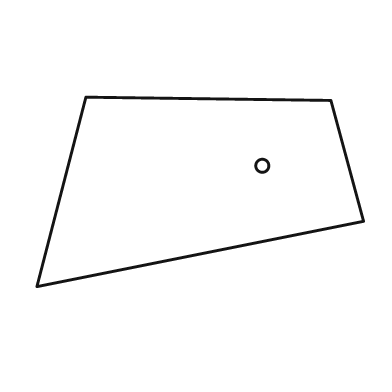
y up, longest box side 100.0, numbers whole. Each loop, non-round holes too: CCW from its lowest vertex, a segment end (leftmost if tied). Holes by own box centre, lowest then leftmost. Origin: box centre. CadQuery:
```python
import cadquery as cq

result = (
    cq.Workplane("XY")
    .moveTo(-50.0, -29.0)
    .lineTo(50.0, -9.0)
    .lineTo(40.0, 28.0)
    .lineTo(-35.0, 29.0)
    .close()
    .moveTo(19.0, 8.0)
    .circle(2.0)
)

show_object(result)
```